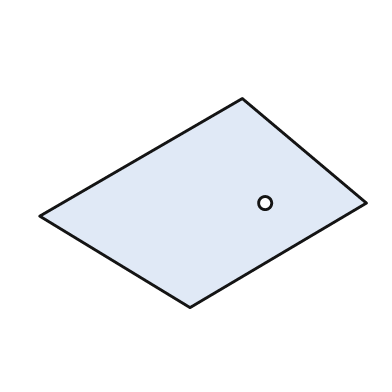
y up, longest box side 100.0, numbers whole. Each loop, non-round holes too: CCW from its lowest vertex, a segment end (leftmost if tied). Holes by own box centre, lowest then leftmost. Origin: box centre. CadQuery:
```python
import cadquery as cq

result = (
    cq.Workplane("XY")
    .moveTo(-4.0, -32.0)
    .lineTo(50.0, 0.0)
    .lineTo(12.0, 32.0)
    .lineTo(-50.0, -4.0)
    .close()
    .moveTo(19.0, 0.0)
    .circle(2.0)
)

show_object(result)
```